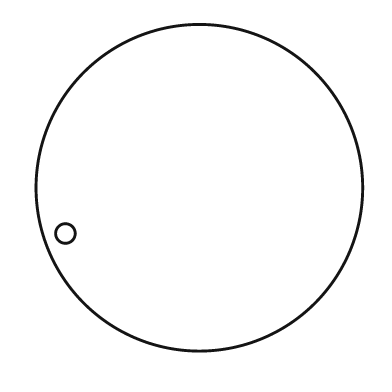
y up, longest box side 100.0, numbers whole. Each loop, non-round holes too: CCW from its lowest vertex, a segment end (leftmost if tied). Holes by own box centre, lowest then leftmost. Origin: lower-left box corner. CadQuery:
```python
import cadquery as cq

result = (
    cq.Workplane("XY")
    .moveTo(50.0, 50.0)
    .circle(50.0)
    .moveTo(9.0, 36.0)
    .circle(3.0)
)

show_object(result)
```